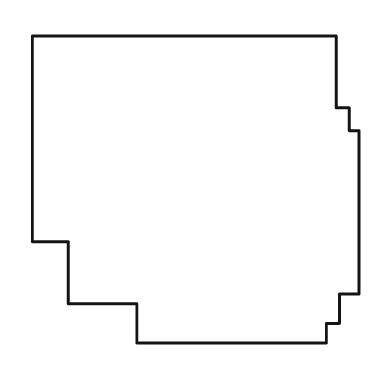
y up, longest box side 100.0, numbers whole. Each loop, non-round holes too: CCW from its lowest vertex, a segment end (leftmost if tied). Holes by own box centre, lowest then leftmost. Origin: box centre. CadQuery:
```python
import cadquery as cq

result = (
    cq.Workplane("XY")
    .moveTo(-18.0, -47.0)
    .lineTo(40.0, -47.0)
    .lineTo(40.0, -41.0)
    .lineTo(44.0, -41.0)
    .lineTo(44.0, -32.0)
    .lineTo(50.0, -32.0)
    .lineTo(50.0, 18.0)
    .lineTo(47.0, 18.0)
    .lineTo(47.0, 25.0)
    .lineTo(43.0, 25.0)
    .lineTo(43.0, 47.0)
    .lineTo(-50.0, 47.0)
    .lineTo(-50.0, -16.0)
    .lineTo(-39.0, -16.0)
    .lineTo(-39.0, -35.0)
    .lineTo(-18.0, -35.0)
    .close()
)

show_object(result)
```